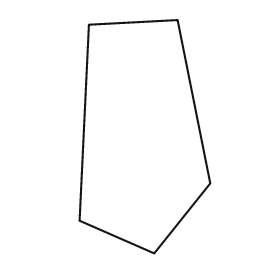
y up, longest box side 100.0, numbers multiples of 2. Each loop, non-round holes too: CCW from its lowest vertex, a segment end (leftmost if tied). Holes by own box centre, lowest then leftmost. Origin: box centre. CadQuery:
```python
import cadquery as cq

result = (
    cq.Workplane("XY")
    .moveTo(4.0, -50.0)
    .lineTo(28.0, -20.0)
    .lineTo(14.0, 50.0)
    .lineTo(-24.0, 48.0)
    .lineTo(-28.0, -36.0)
    .close()
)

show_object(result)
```